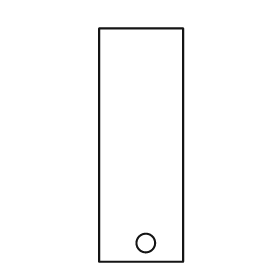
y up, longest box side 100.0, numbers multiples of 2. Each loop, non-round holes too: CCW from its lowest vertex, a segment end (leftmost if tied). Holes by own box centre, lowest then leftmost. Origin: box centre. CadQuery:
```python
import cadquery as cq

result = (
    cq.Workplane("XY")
    .moveTo(-18.0, -50.0)
    .lineTo(18.0, -50.0)
    .lineTo(18.0, 50.0)
    .lineTo(-18.0, 50.0)
    .close()
    .moveTo(2.0, -42.0)
    .circle(4.0)
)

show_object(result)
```